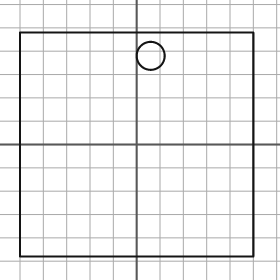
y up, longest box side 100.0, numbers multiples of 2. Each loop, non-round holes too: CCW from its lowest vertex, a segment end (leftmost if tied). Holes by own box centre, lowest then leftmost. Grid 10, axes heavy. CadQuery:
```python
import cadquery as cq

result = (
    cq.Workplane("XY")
    .moveTo(-50.0, -48.0)
    .lineTo(50.0, -48.0)
    .lineTo(50.0, 48.0)
    .lineTo(-50.0, 48.0)
    .close()
    .moveTo(6.0, 38.0)
    .circle(6.0)
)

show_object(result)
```